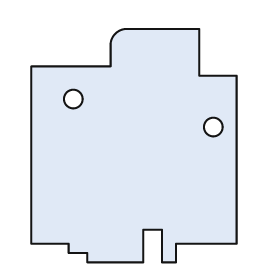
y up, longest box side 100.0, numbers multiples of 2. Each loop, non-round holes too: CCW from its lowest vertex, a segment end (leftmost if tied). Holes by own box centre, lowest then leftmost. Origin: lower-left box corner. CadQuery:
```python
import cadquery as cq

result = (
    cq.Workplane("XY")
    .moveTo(24.0, 0.0)
    .lineTo(48.0, 0.0)
    .lineTo(48.0, 14.0)
    .lineTo(56.0, 14.0)
    .lineTo(56.0, 0.0)
    .lineTo(62.0, 0.0)
    .lineTo(62.0, 8.0)
    .lineTo(88.0, 8.0)
    .lineTo(88.0, 80.0)
    .lineTo(72.0, 80.0)
    .lineTo(72.0, 100.0)
    .lineTo(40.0, 100.0)
    .threePointArc((36.0, 98.0), (34.0, 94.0))
    .lineTo(34.0, 84.0)
    .lineTo(0.0, 84.0)
    .lineTo(0.0, 8.0)
    .lineTo(16.0, 8.0)
    .lineTo(16.0, 4.0)
    .lineTo(24.0, 4.0)
    .close()
    .moveTo(78.0, 58.0)
    .circle(4.0)
    .moveTo(18.0, 70.0)
    .circle(4.0)
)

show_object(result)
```